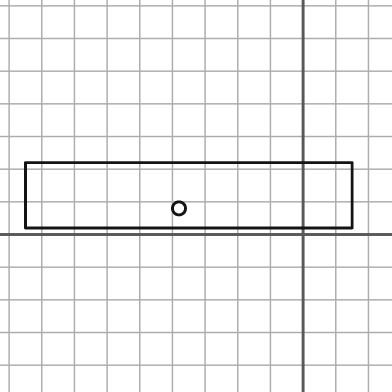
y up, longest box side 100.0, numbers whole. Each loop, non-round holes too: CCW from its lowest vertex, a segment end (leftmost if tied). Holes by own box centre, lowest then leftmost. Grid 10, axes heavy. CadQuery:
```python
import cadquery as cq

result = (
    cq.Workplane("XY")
    .moveTo(-85.0, 2.0)
    .lineTo(15.0, 2.0)
    .lineTo(15.0, 22.0)
    .lineTo(-85.0, 22.0)
    .close()
    .moveTo(-38.0, 8.0)
    .circle(2.0)
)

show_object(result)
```